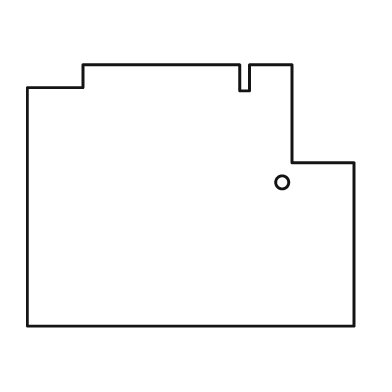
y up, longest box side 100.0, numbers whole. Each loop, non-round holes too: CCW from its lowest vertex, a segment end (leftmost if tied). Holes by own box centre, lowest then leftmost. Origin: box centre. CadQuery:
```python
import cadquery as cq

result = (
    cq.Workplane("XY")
    .moveTo(-50.0, -40.0)
    .lineTo(50.0, -40.0)
    .lineTo(50.0, 10.0)
    .lineTo(31.0, 10.0)
    .lineTo(31.0, 40.0)
    .lineTo(18.0, 40.0)
    .lineTo(18.0, 32.0)
    .lineTo(15.0, 32.0)
    .lineTo(15.0, 40.0)
    .lineTo(-33.0, 40.0)
    .lineTo(-33.0, 33.0)
    .lineTo(-50.0, 33.0)
    .close()
    .moveTo(28.0, 4.0)
    .circle(2.0)
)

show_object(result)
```